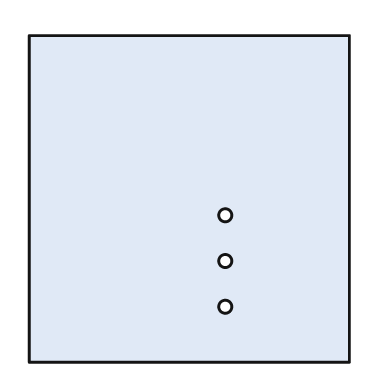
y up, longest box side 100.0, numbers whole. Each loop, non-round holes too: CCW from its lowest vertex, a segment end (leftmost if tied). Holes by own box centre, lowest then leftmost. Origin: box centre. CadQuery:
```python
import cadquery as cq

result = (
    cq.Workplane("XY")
    .moveTo(-49.0, -50.0)
    .lineTo(49.0, -50.0)
    .lineTo(49.0, 50.0)
    .lineTo(-49.0, 50.0)
    .close()
    .moveTo(11.0, -33.0)
    .circle(2.0)
    .moveTo(11.0, -19.0)
    .circle(2.0)
    .moveTo(11.0, -5.0)
    .circle(2.0)
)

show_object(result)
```